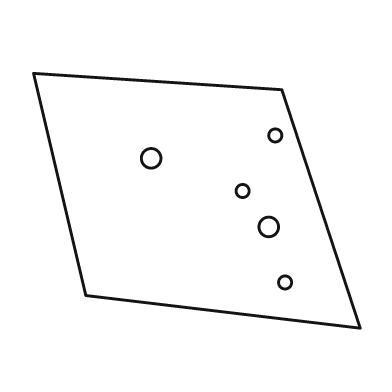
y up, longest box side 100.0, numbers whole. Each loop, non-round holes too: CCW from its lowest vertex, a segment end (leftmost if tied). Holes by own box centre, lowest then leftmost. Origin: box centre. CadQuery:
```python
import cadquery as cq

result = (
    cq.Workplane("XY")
    .moveTo(50.0, -39.0)
    .lineTo(26.0, 34.0)
    .lineTo(-50.0, 39.0)
    .lineTo(-34.0, -29.0)
    .close()
    .moveTo(27.0, -25.0)
    .circle(2.0)
    .moveTo(22.0, -8.0)
    .circle(3.0)
    .moveTo(14.0, 3.0)
    .circle(2.0)
    .moveTo(-14.0, 13.0)
    .circle(3.0)
    .moveTo(24.0, 20.0)
    .circle(2.0)
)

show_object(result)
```